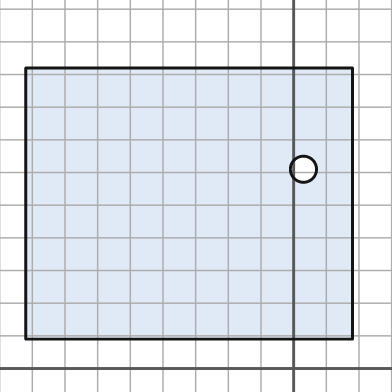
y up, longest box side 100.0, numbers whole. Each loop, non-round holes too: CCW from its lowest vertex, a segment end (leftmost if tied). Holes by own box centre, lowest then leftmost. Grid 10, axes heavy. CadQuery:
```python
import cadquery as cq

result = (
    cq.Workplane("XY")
    .moveTo(-82.0, 9.0)
    .lineTo(18.0, 9.0)
    .lineTo(18.0, 92.0)
    .lineTo(-82.0, 92.0)
    .close()
    .moveTo(3.0, 61.0)
    .circle(4.0)
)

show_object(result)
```